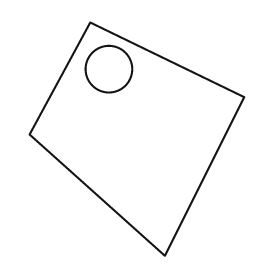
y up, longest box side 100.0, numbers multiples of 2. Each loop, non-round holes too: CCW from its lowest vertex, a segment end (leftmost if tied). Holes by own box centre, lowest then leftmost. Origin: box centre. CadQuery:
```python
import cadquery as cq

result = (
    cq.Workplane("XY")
    .moveTo(12.0, -50.0)
    .lineTo(46.0, 18.0)
    .lineTo(-20.0, 50.0)
    .lineTo(-46.0, 2.0)
    .close()
    .moveTo(-12.0, 30.0)
    .circle(10.0)
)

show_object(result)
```